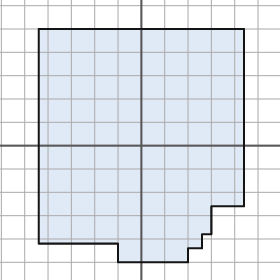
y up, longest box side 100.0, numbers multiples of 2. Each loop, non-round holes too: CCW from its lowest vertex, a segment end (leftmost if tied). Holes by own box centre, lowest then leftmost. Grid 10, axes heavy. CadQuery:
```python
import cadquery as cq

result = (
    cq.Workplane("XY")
    .moveTo(-10.0, -50.0)
    .lineTo(20.0, -50.0)
    .lineTo(20.0, -44.0)
    .lineTo(26.0, -44.0)
    .lineTo(26.0, -38.0)
    .lineTo(30.0, -38.0)
    .lineTo(30.0, -26.0)
    .lineTo(44.0, -26.0)
    .lineTo(44.0, 50.0)
    .lineTo(-44.0, 50.0)
    .lineTo(-44.0, -42.0)
    .lineTo(-10.0, -42.0)
    .close()
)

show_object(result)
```